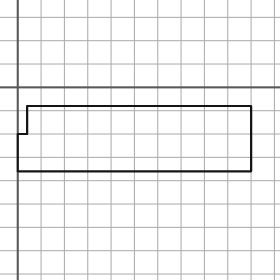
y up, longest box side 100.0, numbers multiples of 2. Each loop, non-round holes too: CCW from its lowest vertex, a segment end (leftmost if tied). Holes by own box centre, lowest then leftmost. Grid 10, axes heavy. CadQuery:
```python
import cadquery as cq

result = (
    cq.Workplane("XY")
    .moveTo(0.0, -36.0)
    .lineTo(100.0, -36.0)
    .lineTo(100.0, -8.0)
    .lineTo(4.0, -8.0)
    .lineTo(4.0, -20.0)
    .lineTo(0.0, -20.0)
    .close()
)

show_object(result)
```